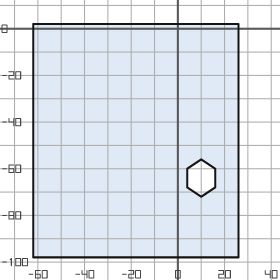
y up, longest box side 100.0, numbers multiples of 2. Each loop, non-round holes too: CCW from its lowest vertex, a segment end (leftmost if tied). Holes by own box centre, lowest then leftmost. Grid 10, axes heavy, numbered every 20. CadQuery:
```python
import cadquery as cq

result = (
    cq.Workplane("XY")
    .moveTo(-62.0, -98.0)
    .lineTo(26.0, -98.0)
    .lineTo(26.0, 2.0)
    .lineTo(-62.0, 2.0)
    .close()
    .moveTo(10.0, -72.0)
    .lineTo(16.0, -68.0)
    .lineTo(16.0, -60.0)
    .lineTo(10.0, -56.0)
    .lineTo(4.0, -60.0)
    .lineTo(4.0, -68.0)
    .close()
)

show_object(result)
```